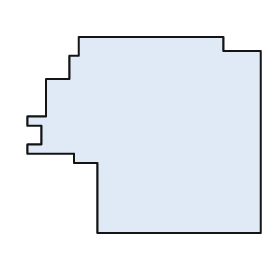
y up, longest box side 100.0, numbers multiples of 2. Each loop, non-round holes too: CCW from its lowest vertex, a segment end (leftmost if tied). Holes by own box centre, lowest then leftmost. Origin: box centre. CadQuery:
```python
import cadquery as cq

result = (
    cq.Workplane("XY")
    .moveTo(-20.0, -42.0)
    .lineTo(50.0, -42.0)
    .lineTo(50.0, 36.0)
    .lineTo(34.0, 36.0)
    .lineTo(34.0, 42.0)
    .lineTo(-28.0, 42.0)
    .lineTo(-28.0, 34.0)
    .lineTo(-32.0, 34.0)
    .lineTo(-32.0, 24.0)
    .lineTo(-42.0, 24.0)
    .lineTo(-42.0, 8.0)
    .lineTo(-50.0, 8.0)
    .lineTo(-50.0, 4.0)
    .lineTo(-44.0, 4.0)
    .lineTo(-44.0, -4.0)
    .lineTo(-50.0, -4.0)
    .lineTo(-50.0, -8.0)
    .lineTo(-30.0, -8.0)
    .lineTo(-30.0, -12.0)
    .lineTo(-20.0, -12.0)
    .close()
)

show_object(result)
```